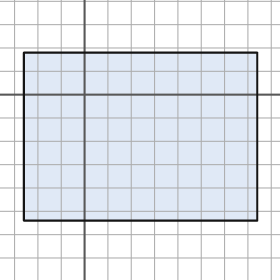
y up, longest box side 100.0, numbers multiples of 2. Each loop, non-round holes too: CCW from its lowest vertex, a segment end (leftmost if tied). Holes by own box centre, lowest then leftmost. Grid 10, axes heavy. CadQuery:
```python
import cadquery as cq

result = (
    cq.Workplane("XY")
    .moveTo(-26.0, -54.0)
    .lineTo(74.0, -54.0)
    .lineTo(74.0, 18.0)
    .lineTo(-26.0, 18.0)
    .close()
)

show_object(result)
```